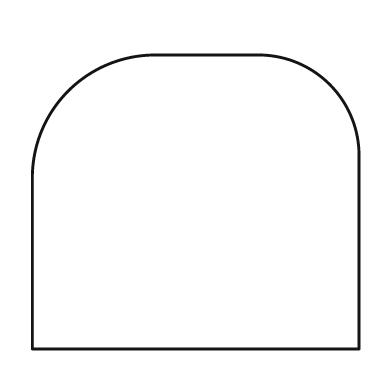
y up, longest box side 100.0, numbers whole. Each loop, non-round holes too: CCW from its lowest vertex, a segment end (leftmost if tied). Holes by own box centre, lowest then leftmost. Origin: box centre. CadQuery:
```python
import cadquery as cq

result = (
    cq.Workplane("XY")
    .moveTo(-50.0, -45.0)
    .lineTo(50.0, -45.0)
    .lineTo(50.0, 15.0)
    .threePointArc((41.0, 36.0), (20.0, 45.0))
    .lineTo(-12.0, 45.0)
    .threePointArc((-39.0, 34.0), (-50.0, 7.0))
    .close()
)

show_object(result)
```